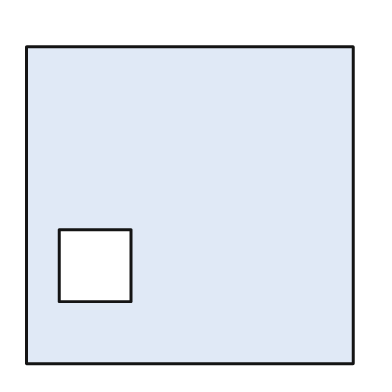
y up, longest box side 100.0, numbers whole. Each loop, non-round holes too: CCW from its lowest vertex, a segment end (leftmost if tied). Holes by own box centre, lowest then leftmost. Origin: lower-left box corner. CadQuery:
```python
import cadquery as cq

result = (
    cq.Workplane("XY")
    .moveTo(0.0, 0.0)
    .lineTo(100.0, 0.0)
    .lineTo(100.0, 97.0)
    .lineTo(0.0, 97.0)
    .close()
    .moveTo(10.0, 19.0)
    .lineTo(32.0, 19.0)
    .lineTo(32.0, 41.0)
    .lineTo(10.0, 41.0)
    .close()
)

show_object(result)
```